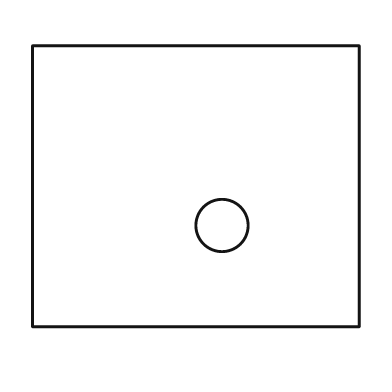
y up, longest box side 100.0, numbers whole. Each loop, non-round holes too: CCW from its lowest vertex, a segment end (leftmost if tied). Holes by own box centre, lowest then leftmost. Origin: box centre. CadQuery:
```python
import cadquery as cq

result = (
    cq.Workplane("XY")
    .moveTo(-50.0, -43.0)
    .lineTo(50.0, -43.0)
    .lineTo(50.0, 43.0)
    .lineTo(-50.0, 43.0)
    .close()
    .moveTo(8.0, -12.0)
    .circle(8.0)
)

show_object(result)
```